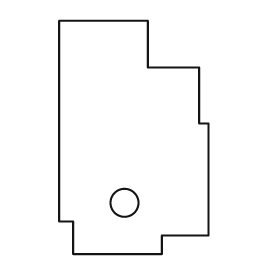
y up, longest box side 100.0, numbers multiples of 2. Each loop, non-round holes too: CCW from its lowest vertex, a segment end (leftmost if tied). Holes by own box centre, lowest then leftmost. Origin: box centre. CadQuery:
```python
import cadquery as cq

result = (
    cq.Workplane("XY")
    .moveTo(-26.0, -50.0)
    .lineTo(12.0, -50.0)
    .lineTo(12.0, -42.0)
    .lineTo(32.0, -42.0)
    .lineTo(32.0, 6.0)
    .lineTo(28.0, 6.0)
    .lineTo(28.0, 30.0)
    .lineTo(6.0, 30.0)
    .lineTo(6.0, 50.0)
    .lineTo(-32.0, 50.0)
    .lineTo(-32.0, -36.0)
    .lineTo(-26.0, -36.0)
    .close()
    .moveTo(-4.0, -28.0)
    .circle(6.0)
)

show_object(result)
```